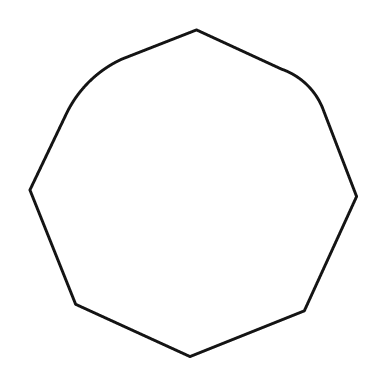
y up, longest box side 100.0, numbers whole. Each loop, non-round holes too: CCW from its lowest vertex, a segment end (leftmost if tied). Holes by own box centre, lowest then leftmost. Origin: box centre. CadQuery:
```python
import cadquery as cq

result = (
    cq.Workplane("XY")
    .moveTo(-1.0, -50.0)
    .lineTo(34.0, -36.0)
    .lineTo(50.0, -1.0)
    .lineTo(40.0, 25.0)
    .threePointArc((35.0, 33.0), (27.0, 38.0))
    .lineTo(1.0, 50.0)
    .lineTo(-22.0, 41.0)
    .threePointArc((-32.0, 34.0), (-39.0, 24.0))
    .lineTo(-50.0, 1.0)
    .lineTo(-36.0, -34.0)
    .close()
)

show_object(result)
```